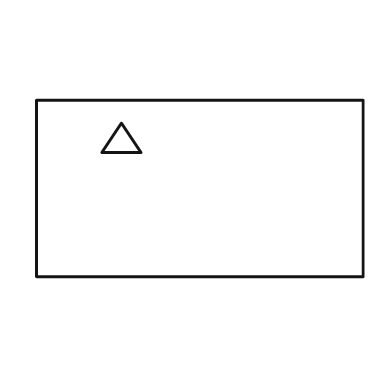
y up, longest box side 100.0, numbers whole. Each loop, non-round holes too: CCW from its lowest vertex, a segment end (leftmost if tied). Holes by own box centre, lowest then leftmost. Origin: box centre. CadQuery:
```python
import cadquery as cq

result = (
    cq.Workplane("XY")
    .moveTo(-50.0, -27.0)
    .lineTo(50.0, -27.0)
    .lineTo(50.0, 27.0)
    .lineTo(-50.0, 27.0)
    .close()
    .moveTo(-30.0, 11.0)
    .lineTo(-18.0, 11.0)
    .lineTo(-24.0, 20.0)
    .close()
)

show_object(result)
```